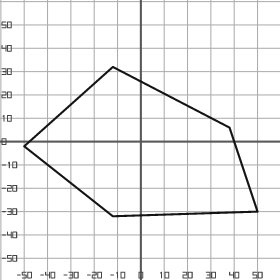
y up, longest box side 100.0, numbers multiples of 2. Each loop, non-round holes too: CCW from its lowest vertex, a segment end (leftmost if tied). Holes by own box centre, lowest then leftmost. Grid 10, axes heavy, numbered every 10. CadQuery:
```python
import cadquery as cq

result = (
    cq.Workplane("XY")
    .moveTo(-12.0, -32.0)
    .lineTo(50.0, -30.0)
    .lineTo(38.0, 6.0)
    .lineTo(-12.0, 32.0)
    .lineTo(-50.0, -2.0)
    .close()
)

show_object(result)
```